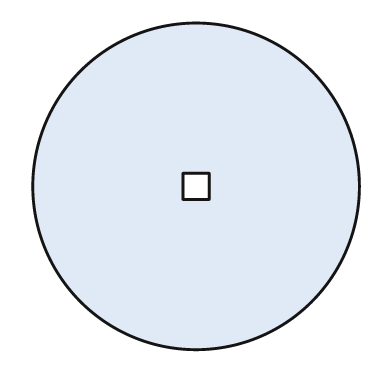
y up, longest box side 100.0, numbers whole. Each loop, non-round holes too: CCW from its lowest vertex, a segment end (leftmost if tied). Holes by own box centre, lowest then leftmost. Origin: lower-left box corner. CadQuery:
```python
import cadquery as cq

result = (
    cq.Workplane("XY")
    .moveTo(50.0, 50.0)
    .circle(50.0)
    .moveTo(46.0, 46.0)
    .lineTo(54.0, 46.0)
    .lineTo(54.0, 54.0)
    .lineTo(46.0, 54.0)
    .close()
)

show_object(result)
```